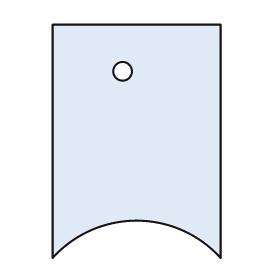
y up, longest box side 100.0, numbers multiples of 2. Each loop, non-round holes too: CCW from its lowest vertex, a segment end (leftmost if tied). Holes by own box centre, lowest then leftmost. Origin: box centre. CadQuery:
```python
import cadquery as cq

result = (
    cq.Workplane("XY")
    .moveTo(-36.0, -50.0)
    .threePointArc((0.0, -34.0), (36.0, -50.0))
    .lineTo(36.0, 50.0)
    .lineTo(-36.0, 50.0)
    .close()
    .moveTo(-6.0, 30.0)
    .circle(4.0)
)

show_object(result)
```